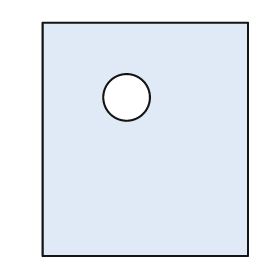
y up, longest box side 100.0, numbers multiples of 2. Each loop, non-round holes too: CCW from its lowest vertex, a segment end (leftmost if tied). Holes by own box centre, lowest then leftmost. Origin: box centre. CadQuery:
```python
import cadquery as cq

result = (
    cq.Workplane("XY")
    .moveTo(-44.0, -50.0)
    .lineTo(44.0, -50.0)
    .lineTo(44.0, 50.0)
    .lineTo(-44.0, 50.0)
    .close()
    .moveTo(-8.0, 18.0)
    .circle(10.0)
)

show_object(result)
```